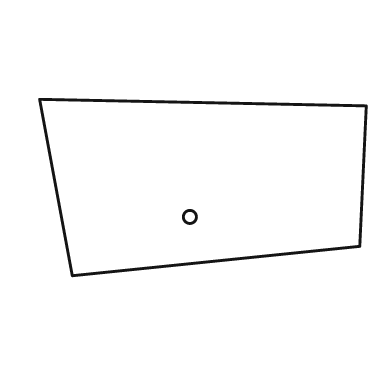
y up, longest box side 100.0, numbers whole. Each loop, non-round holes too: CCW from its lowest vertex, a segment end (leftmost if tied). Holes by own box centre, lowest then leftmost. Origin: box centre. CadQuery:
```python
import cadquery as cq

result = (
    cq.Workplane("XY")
    .moveTo(-40.0, -27.0)
    .lineTo(48.0, -18.0)
    .lineTo(50.0, 25.0)
    .lineTo(-50.0, 27.0)
    .close()
    .moveTo(-4.0, -9.0)
    .circle(2.0)
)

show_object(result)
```